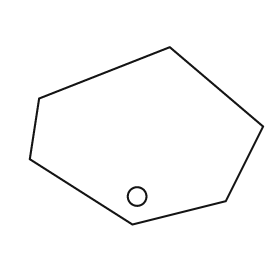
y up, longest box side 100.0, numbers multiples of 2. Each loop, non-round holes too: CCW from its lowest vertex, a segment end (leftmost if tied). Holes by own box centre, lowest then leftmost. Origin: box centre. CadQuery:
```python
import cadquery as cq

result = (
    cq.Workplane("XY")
    .moveTo(-6.0, -38.0)
    .lineTo(34.0, -28.0)
    .lineTo(50.0, 4.0)
    .lineTo(10.0, 38.0)
    .lineTo(-46.0, 16.0)
    .lineTo(-50.0, -10.0)
    .close()
    .moveTo(-4.0, -26.0)
    .circle(4.0)
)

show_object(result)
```